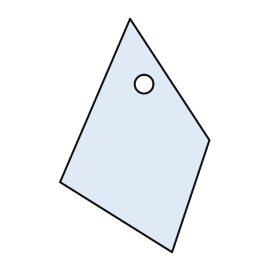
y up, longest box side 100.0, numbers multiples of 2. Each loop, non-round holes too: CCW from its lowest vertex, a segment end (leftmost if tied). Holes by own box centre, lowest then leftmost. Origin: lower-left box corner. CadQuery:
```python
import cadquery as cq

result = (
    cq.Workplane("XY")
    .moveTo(48.0, 0.0)
    .lineTo(64.0, 48.0)
    .lineTo(30.0, 100.0)
    .lineTo(0.0, 30.0)
    .close()
    .moveTo(36.0, 72.0)
    .circle(4.0)
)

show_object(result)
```